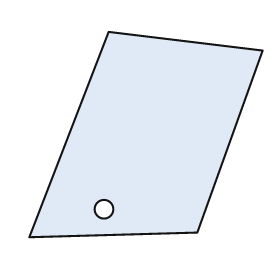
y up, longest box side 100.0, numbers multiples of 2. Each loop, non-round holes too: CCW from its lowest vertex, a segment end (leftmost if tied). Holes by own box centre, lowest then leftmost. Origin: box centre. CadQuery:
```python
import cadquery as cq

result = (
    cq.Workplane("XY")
    .moveTo(-50.0, -44.0)
    .lineTo(22.0, -42.0)
    .lineTo(50.0, 36.0)
    .lineTo(-16.0, 44.0)
    .close()
    .moveTo(-18.0, -32.0)
    .circle(4.0)
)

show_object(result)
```